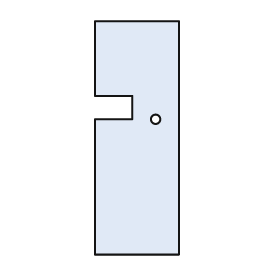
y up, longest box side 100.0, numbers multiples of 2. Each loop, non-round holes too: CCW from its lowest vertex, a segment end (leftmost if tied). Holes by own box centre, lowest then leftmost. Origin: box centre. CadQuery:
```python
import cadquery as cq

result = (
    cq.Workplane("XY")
    .moveTo(-18.0, -50.0)
    .lineTo(18.0, -50.0)
    .lineTo(18.0, 50.0)
    .lineTo(-18.0, 50.0)
    .lineTo(-18.0, 18.0)
    .lineTo(-2.0, 18.0)
    .lineTo(-2.0, 8.0)
    .lineTo(-18.0, 8.0)
    .close()
    .moveTo(8.0, 8.0)
    .circle(2.0)
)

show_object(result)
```